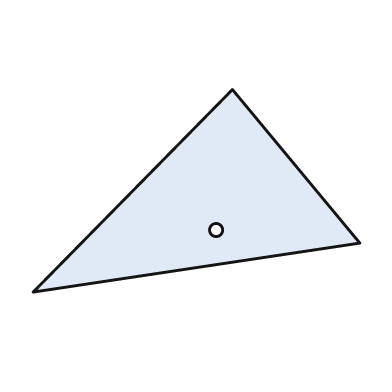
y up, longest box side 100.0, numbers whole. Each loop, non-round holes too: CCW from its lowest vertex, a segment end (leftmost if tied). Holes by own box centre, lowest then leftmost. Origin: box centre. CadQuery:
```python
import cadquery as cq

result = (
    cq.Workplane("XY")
    .moveTo(-50.0, -31.0)
    .lineTo(50.0, -16.0)
    .lineTo(11.0, 31.0)
    .close()
    .moveTo(6.0, -12.0)
    .circle(2.0)
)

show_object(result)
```